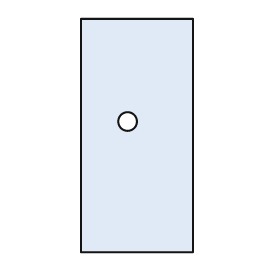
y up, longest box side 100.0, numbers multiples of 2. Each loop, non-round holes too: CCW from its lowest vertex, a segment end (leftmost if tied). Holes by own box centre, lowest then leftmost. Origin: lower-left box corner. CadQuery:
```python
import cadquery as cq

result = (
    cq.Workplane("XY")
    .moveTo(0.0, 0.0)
    .lineTo(48.0, 0.0)
    .lineTo(48.0, 100.0)
    .lineTo(0.0, 100.0)
    .close()
    .moveTo(20.0, 56.0)
    .circle(4.0)
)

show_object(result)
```